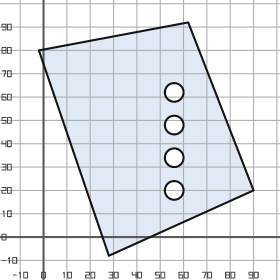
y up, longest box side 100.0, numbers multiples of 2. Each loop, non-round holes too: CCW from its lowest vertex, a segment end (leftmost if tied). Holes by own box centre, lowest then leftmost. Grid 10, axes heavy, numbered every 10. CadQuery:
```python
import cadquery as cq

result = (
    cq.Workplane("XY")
    .moveTo(28.0, -8.0)
    .lineTo(90.0, 20.0)
    .lineTo(62.0, 92.0)
    .lineTo(-2.0, 80.0)
    .close()
    .moveTo(56.0, 20.0)
    .circle(4.0)
    .moveTo(56.0, 34.0)
    .circle(4.0)
    .moveTo(56.0, 48.0)
    .circle(4.0)
    .moveTo(56.0, 62.0)
    .circle(4.0)
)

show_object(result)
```